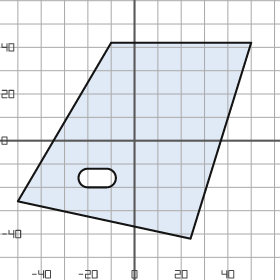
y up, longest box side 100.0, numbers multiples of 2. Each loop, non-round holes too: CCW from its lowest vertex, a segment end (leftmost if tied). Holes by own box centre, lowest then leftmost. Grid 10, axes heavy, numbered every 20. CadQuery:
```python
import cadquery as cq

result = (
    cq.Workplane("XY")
    .moveTo(24.0, -42.0)
    .lineTo(50.0, 42.0)
    .lineTo(-10.0, 42.0)
    .lineTo(-50.0, -26.0)
    .close()
    .moveTo(-20.0, -20.0)
    .lineTo(-12.0, -20.0)
    .threePointArc((-8.0, -16.0), (-12.0, -12.0))
    .lineTo(-20.0, -12.0)
    .threePointArc((-24.0, -16.0), (-20.0, -20.0))
    .close()
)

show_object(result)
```